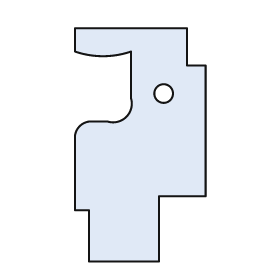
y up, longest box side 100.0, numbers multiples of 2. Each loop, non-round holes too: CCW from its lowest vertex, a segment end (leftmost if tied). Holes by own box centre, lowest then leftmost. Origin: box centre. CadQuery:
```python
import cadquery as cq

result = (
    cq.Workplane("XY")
    .moveTo(-22.0, -50.0)
    .lineTo(8.0, -50.0)
    .lineTo(8.0, -22.0)
    .lineTo(28.0, -22.0)
    .lineTo(28.0, 34.0)
    .lineTo(20.0, 34.0)
    .lineTo(20.0, 50.0)
    .lineTo(-28.0, 50.0)
    .lineTo(-28.0, 40.0)
    .threePointArc((-16.0, 38.0), (-4.0, 40.0))
    .lineTo(-4.0, 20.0)
    .threePointArc((-6.0, 12.0), (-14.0, 10.0))
    .lineTo(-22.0, 10.0)
    .threePointArc((-26.0, 8.0), (-28.0, 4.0))
    .lineTo(-28.0, -28.0)
    .lineTo(-22.0, -28.0)
    .close()
    .moveTo(10.0, 22.0)
    .circle(4.0)
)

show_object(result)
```